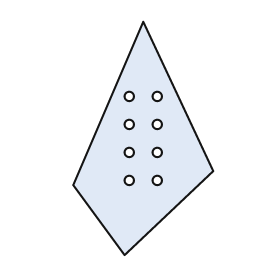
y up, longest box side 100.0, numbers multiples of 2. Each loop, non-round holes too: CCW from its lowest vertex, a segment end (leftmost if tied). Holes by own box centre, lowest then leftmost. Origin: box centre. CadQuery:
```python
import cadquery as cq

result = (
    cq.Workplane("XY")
    .moveTo(-8.0, -50.0)
    .lineTo(30.0, -14.0)
    .lineTo(0.0, 50.0)
    .lineTo(-30.0, -20.0)
    .close()
    .moveTo(-6.0, -18.0)
    .circle(2.0)
    .moveTo(6.0, -18.0)
    .circle(2.0)
    .moveTo(-6.0, -6.0)
    .circle(2.0)
    .moveTo(6.0, -6.0)
    .circle(2.0)
    .moveTo(-6.0, 6.0)
    .circle(2.0)
    .moveTo(6.0, 6.0)
    .circle(2.0)
    .moveTo(-6.0, 18.0)
    .circle(2.0)
    .moveTo(6.0, 18.0)
    .circle(2.0)
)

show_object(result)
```